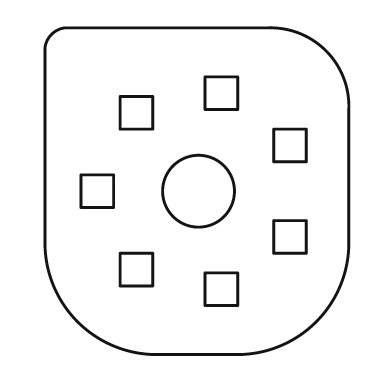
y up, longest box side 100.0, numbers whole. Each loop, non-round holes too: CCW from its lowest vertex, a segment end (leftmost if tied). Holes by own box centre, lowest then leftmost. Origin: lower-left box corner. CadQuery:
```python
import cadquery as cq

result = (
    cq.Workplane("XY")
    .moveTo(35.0, 0.0)
    .lineTo(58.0, 0.0)
    .threePointArc((83.0, 10.0), (93.0, 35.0))
    .lineTo(93.0, 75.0)
    .threePointArc((86.0, 93.0), (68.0, 100.0))
    .lineTo(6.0, 100.0)
    .threePointArc((2.0, 98.0), (0.0, 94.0))
    .lineTo(0.0, 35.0)
    .threePointArc((10.0, 10.0), (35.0, 0.0))
    .close()
    .moveTo(49.0, 15.0)
    .lineTo(59.0, 15.0)
    .lineTo(59.0, 25.0)
    .lineTo(49.0, 25.0)
    .close()
    .moveTo(23.0, 21.0)
    .lineTo(33.0, 21.0)
    .lineTo(33.0, 31.0)
    .lineTo(23.0, 31.0)
    .close()
    .moveTo(70.0, 31.0)
    .lineTo(80.0, 31.0)
    .lineTo(80.0, 41.0)
    .lineTo(70.0, 41.0)
    .close()
    .moveTo(11.0, 45.0)
    .lineTo(21.0, 45.0)
    .lineTo(21.0, 55.0)
    .lineTo(11.0, 55.0)
    .close()
    .moveTo(47.0, 50.0)
    .circle(11.0)
    .moveTo(70.0, 59.0)
    .lineTo(80.0, 59.0)
    .lineTo(80.0, 69.0)
    .lineTo(70.0, 69.0)
    .close()
    .moveTo(23.0, 69.0)
    .lineTo(33.0, 69.0)
    .lineTo(33.0, 79.0)
    .lineTo(23.0, 79.0)
    .close()
    .moveTo(49.0, 75.0)
    .lineTo(59.0, 75.0)
    .lineTo(59.0, 85.0)
    .lineTo(49.0, 85.0)
    .close()
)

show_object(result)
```